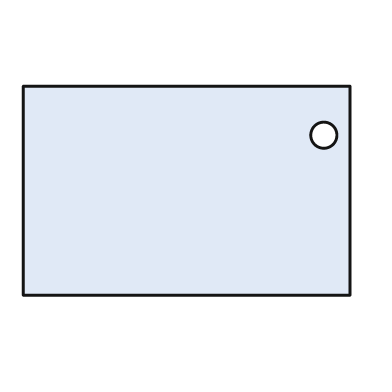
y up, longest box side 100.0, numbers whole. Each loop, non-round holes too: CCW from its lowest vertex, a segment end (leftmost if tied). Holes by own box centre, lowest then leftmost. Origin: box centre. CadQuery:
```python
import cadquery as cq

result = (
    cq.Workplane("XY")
    .moveTo(-50.0, -32.0)
    .lineTo(50.0, -32.0)
    .lineTo(50.0, 32.0)
    .lineTo(-50.0, 32.0)
    .close()
    .moveTo(42.0, 17.0)
    .circle(4.0)
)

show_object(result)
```